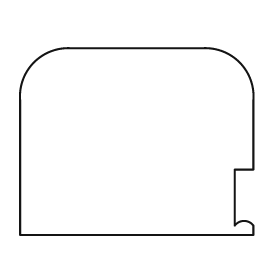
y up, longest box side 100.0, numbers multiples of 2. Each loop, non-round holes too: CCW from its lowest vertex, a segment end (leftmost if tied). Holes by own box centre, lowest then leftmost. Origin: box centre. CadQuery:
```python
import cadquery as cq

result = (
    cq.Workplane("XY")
    .moveTo(-50.0, -40.0)
    .lineTo(50.0, -40.0)
    .lineTo(50.0, -36.0)
    .threePointArc((46.0, -34.0), (42.0, -36.0))
    .lineTo(42.0, -12.0)
    .lineTo(50.0, -12.0)
    .lineTo(50.0, 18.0)
    .threePointArc((44.0, 34.0), (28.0, 40.0))
    .lineTo(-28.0, 40.0)
    .threePointArc((-44.0, 34.0), (-50.0, 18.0))
    .close()
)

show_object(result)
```